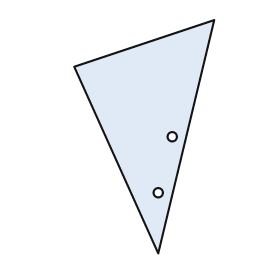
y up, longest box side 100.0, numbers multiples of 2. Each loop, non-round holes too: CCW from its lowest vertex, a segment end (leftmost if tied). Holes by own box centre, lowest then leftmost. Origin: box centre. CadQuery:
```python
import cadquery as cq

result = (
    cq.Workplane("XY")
    .moveTo(6.0, -50.0)
    .lineTo(30.0, 50.0)
    .lineTo(-30.0, 30.0)
    .close()
    .moveTo(6.0, -24.0)
    .circle(2.0)
    .moveTo(12.0, 0.0)
    .circle(2.0)
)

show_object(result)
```